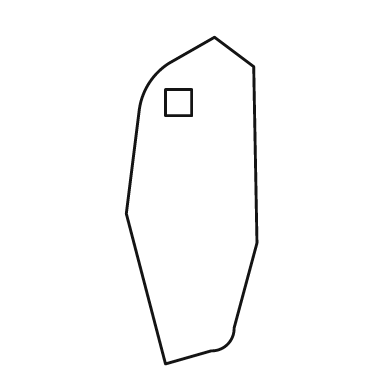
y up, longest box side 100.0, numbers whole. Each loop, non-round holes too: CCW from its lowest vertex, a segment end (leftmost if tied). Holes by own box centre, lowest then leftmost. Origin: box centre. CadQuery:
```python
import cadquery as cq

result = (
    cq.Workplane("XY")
    .moveTo(-8.0, -50.0)
    .lineTo(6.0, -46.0)
    .threePointArc((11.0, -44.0), (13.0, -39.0))
    .lineTo(20.0, -13.0)
    .lineTo(19.0, 41.0)
    .lineTo(7.0, 50.0)
    .lineTo(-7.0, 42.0)
    .threePointArc((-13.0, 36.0), (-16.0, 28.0))
    .lineTo(-20.0, -4.0)
    .close()
    .moveTo(-8.0, 26.0)
    .lineTo(0.0, 26.0)
    .lineTo(0.0, 34.0)
    .lineTo(-8.0, 34.0)
    .close()
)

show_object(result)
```